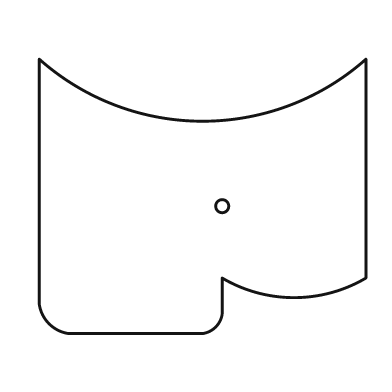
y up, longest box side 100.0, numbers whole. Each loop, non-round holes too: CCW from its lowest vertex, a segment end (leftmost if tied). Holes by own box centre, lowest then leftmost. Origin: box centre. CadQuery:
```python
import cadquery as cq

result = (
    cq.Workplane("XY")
    .moveTo(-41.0, -42.0)
    .lineTo(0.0, -42.0)
    .threePointArc((4.0, -40.0), (6.0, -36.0))
    .lineTo(6.0, -25.0)
    .threePointArc((28.0, -31.0), (50.0, -25.0))
    .lineTo(50.0, 42.0)
    .threePointArc((0.0, 23.0), (-50.0, 42.0))
    .lineTo(-50.0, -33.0)
    .threePointArc((-47.0, -39.0), (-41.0, -42.0))
    .close()
    .moveTo(6.0, -3.0)
    .circle(2.0)
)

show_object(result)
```